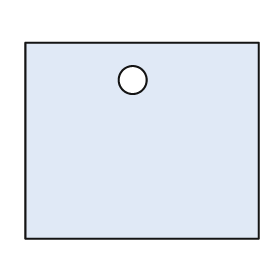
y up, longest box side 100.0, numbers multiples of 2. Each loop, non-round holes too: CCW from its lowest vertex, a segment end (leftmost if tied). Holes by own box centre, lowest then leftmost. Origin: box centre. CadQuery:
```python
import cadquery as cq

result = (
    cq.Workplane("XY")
    .moveTo(-50.0, -42.0)
    .lineTo(50.0, -42.0)
    .lineTo(50.0, 42.0)
    .lineTo(-50.0, 42.0)
    .close()
    .moveTo(-4.0, 26.0)
    .circle(6.0)
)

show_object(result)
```